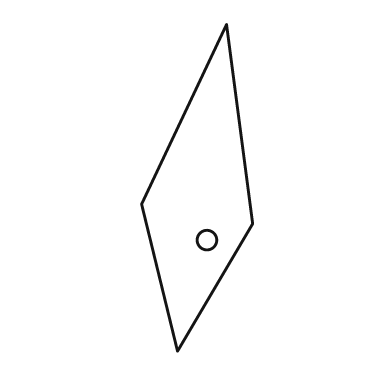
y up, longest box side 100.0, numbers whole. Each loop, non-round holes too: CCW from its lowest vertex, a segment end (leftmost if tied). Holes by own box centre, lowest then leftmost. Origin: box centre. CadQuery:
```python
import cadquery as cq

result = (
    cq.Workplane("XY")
    .moveTo(-6.0, -50.0)
    .lineTo(17.0, -11.0)
    .lineTo(9.0, 50.0)
    .lineTo(-17.0, -5.0)
    .close()
    .moveTo(3.0, -16.0)
    .circle(3.0)
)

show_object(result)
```